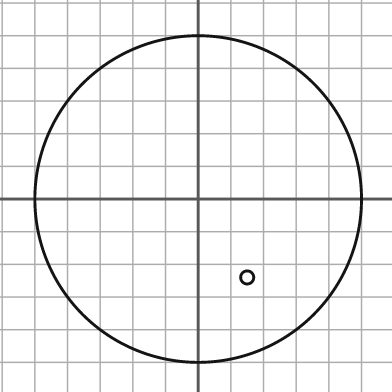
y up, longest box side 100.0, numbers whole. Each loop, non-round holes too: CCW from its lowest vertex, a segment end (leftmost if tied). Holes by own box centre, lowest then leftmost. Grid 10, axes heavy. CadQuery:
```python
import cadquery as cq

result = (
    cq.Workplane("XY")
    .moveTo(0.0, 0.0)
    .circle(50.0)
    .moveTo(15.0, -24.0)
    .circle(2.0)
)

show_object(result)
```